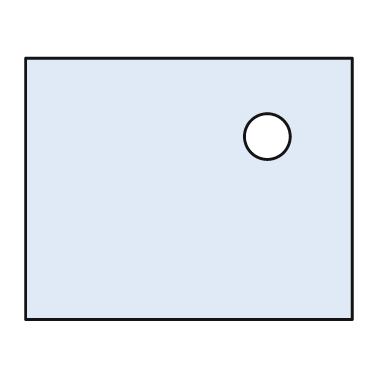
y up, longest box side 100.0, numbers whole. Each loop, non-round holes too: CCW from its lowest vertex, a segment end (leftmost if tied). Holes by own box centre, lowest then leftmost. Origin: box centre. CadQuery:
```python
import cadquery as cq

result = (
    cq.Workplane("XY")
    .moveTo(-50.0, -40.0)
    .lineTo(50.0, -40.0)
    .lineTo(50.0, 40.0)
    .lineTo(-50.0, 40.0)
    .close()
    .moveTo(24.0, 16.0)
    .circle(7.0)
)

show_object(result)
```